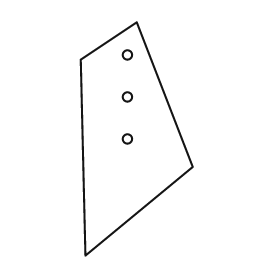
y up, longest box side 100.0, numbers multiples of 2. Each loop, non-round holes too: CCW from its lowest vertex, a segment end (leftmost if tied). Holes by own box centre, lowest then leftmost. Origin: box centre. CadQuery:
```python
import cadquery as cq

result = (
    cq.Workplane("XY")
    .moveTo(-22.0, -50.0)
    .lineTo(24.0, -12.0)
    .lineTo(0.0, 50.0)
    .lineTo(-24.0, 34.0)
    .close()
    .moveTo(-4.0, 0.0)
    .circle(2.0)
    .moveTo(-4.0, 18.0)
    .circle(2.0)
    .moveTo(-4.0, 36.0)
    .circle(2.0)
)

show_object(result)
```